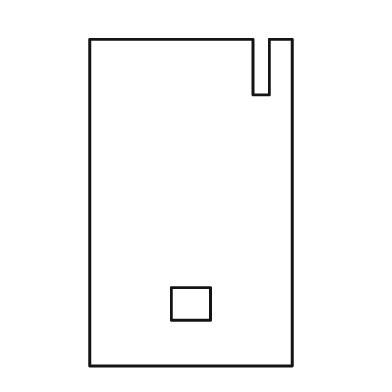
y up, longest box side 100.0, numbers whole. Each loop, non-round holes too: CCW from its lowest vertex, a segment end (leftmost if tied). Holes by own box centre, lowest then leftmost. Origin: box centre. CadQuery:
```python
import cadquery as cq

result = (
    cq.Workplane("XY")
    .moveTo(-31.0, -50.0)
    .lineTo(31.0, -50.0)
    .lineTo(31.0, 50.0)
    .lineTo(24.0, 50.0)
    .lineTo(24.0, 33.0)
    .lineTo(19.0, 33.0)
    .lineTo(19.0, 50.0)
    .lineTo(-31.0, 50.0)
    .close()
    .moveTo(-6.0, -36.0)
    .lineTo(6.0, -36.0)
    .lineTo(6.0, -26.0)
    .lineTo(-6.0, -26.0)
    .close()
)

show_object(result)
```